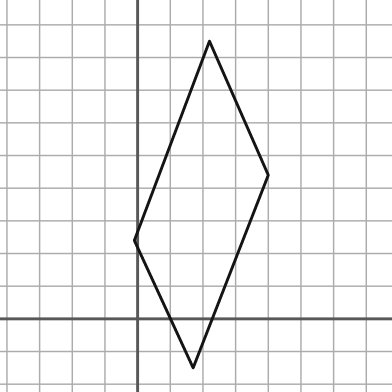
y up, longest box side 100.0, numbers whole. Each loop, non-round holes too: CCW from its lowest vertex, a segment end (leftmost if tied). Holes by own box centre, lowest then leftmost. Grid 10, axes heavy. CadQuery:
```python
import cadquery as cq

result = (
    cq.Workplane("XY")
    .moveTo(17.0, -15.0)
    .lineTo(40.0, 44.0)
    .lineTo(22.0, 85.0)
    .lineTo(-1.0, 24.0)
    .close()
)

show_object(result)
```